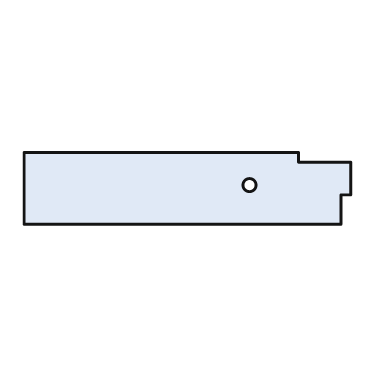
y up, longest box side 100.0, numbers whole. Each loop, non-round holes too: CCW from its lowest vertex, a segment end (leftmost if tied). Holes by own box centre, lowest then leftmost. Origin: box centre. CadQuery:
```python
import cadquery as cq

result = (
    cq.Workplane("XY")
    .moveTo(-50.0, -11.0)
    .lineTo(47.0, -11.0)
    .lineTo(47.0, -2.0)
    .lineTo(50.0, -2.0)
    .lineTo(50.0, 8.0)
    .lineTo(34.0, 8.0)
    .lineTo(34.0, 11.0)
    .lineTo(-50.0, 11.0)
    .close()
    .moveTo(19.0, 1.0)
    .circle(2.0)
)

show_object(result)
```